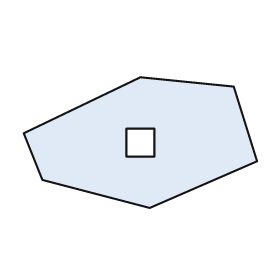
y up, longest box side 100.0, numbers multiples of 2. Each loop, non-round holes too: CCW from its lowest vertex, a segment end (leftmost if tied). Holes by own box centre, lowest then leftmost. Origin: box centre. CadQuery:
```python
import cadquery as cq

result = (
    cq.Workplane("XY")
    .moveTo(4.0, -28.0)
    .lineTo(50.0, -8.0)
    .lineTo(40.0, 24.0)
    .lineTo(0.0, 28.0)
    .lineTo(-50.0, 4.0)
    .lineTo(-42.0, -16.0)
    .close()
    .moveTo(-6.0, -6.0)
    .lineTo(6.0, -6.0)
    .lineTo(6.0, 6.0)
    .lineTo(-6.0, 6.0)
    .close()
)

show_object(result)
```